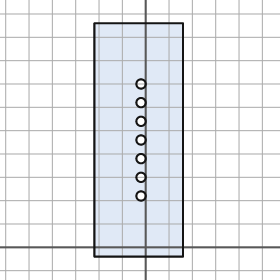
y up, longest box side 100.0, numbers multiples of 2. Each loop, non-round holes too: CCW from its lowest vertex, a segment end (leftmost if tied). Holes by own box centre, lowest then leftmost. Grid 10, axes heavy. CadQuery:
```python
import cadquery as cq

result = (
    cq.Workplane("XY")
    .moveTo(-22.0, -4.0)
    .lineTo(16.0, -4.0)
    .lineTo(16.0, 96.0)
    .lineTo(-22.0, 96.0)
    .close()
    .moveTo(-2.0, 22.0)
    .circle(2.0)
    .moveTo(-2.0, 30.0)
    .circle(2.0)
    .moveTo(-2.0, 38.0)
    .circle(2.0)
    .moveTo(-2.0, 46.0)
    .circle(2.0)
    .moveTo(-2.0, 54.0)
    .circle(2.0)
    .moveTo(-2.0, 62.0)
    .circle(2.0)
    .moveTo(-2.0, 70.0)
    .circle(2.0)
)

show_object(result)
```